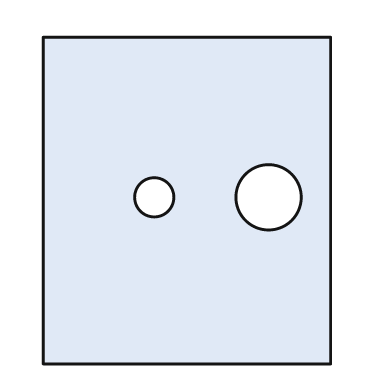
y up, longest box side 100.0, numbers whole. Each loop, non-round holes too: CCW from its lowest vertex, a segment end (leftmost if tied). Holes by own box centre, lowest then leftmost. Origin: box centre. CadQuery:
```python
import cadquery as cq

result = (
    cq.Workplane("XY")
    .moveTo(-44.0, -50.0)
    .lineTo(44.0, -50.0)
    .lineTo(44.0, 50.0)
    .lineTo(-44.0, 50.0)
    .close()
    .moveTo(-10.0, 1.0)
    .circle(6.0)
    .moveTo(25.0, 1.0)
    .circle(10.0)
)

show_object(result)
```